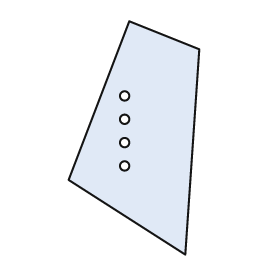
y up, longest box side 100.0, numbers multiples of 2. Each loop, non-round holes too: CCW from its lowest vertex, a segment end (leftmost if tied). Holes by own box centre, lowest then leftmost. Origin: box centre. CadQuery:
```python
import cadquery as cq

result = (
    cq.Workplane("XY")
    .moveTo(22.0, -50.0)
    .lineTo(28.0, 38.0)
    .lineTo(-2.0, 50.0)
    .lineTo(-28.0, -18.0)
    .close()
    .moveTo(-4.0, -12.0)
    .circle(2.0)
    .moveTo(-4.0, -2.0)
    .circle(2.0)
    .moveTo(-4.0, 8.0)
    .circle(2.0)
    .moveTo(-4.0, 18.0)
    .circle(2.0)
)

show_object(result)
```